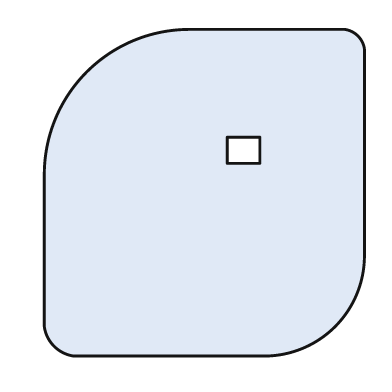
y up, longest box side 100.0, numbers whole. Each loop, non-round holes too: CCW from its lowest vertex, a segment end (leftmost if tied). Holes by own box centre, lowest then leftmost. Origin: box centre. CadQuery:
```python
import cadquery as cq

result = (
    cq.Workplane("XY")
    .moveTo(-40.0, -50.0)
    .lineTo(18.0, -50.0)
    .threePointArc((40.0, -41.0), (49.0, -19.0))
    .lineTo(49.0, 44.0)
    .threePointArc((47.0, 48.0), (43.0, 50.0))
    .lineTo(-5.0, 50.0)
    .threePointArc((-36.0, 37.0), (-49.0, 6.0))
    .lineTo(-49.0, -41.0)
    .threePointArc((-46.0, -47.0), (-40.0, -50.0))
    .close()
    .moveTo(7.0, 9.0)
    .lineTo(17.0, 9.0)
    .lineTo(17.0, 17.0)
    .lineTo(7.0, 17.0)
    .close()
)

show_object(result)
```